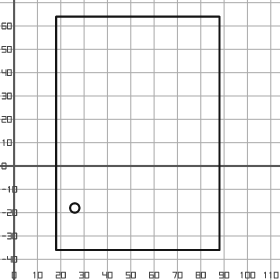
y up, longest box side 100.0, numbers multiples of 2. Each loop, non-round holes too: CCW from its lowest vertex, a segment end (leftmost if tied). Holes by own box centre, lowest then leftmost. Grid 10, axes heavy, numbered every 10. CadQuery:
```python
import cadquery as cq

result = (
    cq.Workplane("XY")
    .moveTo(18.0, -36.0)
    .lineTo(88.0, -36.0)
    .lineTo(88.0, 64.0)
    .lineTo(18.0, 64.0)
    .close()
    .moveTo(26.0, -18.0)
    .circle(2.0)
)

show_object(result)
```